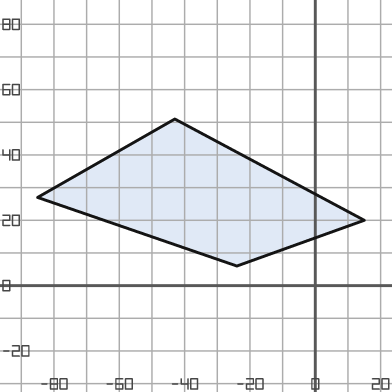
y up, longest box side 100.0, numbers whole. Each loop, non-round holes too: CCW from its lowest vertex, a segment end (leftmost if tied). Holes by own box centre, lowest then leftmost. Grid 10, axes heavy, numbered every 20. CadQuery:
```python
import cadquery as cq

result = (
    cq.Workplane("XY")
    .moveTo(-24.0, 6.0)
    .lineTo(15.0, 20.0)
    .lineTo(-43.0, 51.0)
    .lineTo(-85.0, 27.0)
    .close()
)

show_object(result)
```